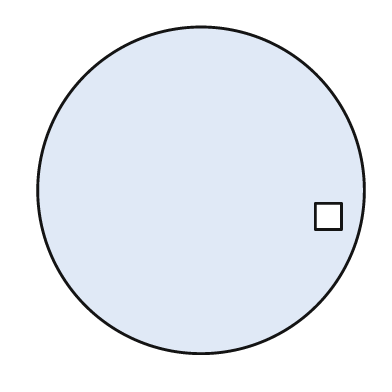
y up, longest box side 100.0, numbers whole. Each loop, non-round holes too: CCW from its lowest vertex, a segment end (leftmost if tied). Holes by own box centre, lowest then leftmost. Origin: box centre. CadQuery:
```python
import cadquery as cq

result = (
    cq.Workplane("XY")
    .moveTo(0.0, 0.0)
    .circle(50.0)
    .moveTo(35.0, -12.0)
    .lineTo(43.0, -12.0)
    .lineTo(43.0, -4.0)
    .lineTo(35.0, -4.0)
    .close()
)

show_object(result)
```